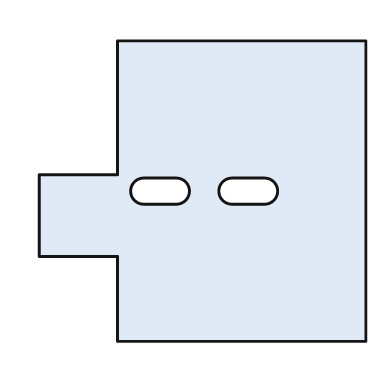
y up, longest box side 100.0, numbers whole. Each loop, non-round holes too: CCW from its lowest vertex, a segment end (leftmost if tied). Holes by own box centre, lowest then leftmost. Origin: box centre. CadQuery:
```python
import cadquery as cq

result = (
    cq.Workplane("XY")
    .moveTo(-26.0, -46.0)
    .lineTo(50.0, -46.0)
    .lineTo(50.0, 46.0)
    .lineTo(-26.0, 46.0)
    .lineTo(-26.0, 5.0)
    .lineTo(-50.0, 5.0)
    .lineTo(-50.0, -20.0)
    .lineTo(-26.0, -20.0)
    .close()
    .moveTo(-18.0, -4.0)
    .lineTo(-8.0, -4.0)
    .threePointArc((-4.0, 0.0), (-8.0, 4.0))
    .lineTo(-18.0, 4.0)
    .threePointArc((-22.0, 0.0), (-18.0, -4.0))
    .close()
    .moveTo(9.0, -4.0)
    .lineTo(19.0, -4.0)
    .threePointArc((23.0, 0.0), (19.0, 4.0))
    .lineTo(9.0, 4.0)
    .threePointArc((5.0, 0.0), (9.0, -4.0))
    .close()
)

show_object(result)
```